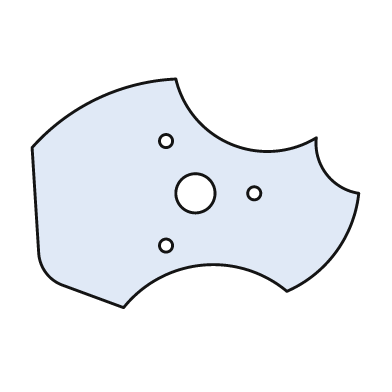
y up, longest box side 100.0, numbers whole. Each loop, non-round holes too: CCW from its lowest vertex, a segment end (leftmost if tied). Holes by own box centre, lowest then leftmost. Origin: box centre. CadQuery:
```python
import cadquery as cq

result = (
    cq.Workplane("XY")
    .moveTo(-22.0, -35.0)
    .threePointArc((2.0, -22.0), (28.0, -30.0))
    .threePointArc((43.0, -18.0), (50.0, 0.0))
    .threePointArc((40.0, 6.0), (37.0, 17.0))
    .threePointArc((11.0, 15.0), (-6.0, 35.0))
    .threePointArc((-30.0, 29.0), (-50.0, 14.0))
    .lineTo(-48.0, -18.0)
    .threePointArc((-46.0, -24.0), (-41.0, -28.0))
    .close()
    .moveTo(-9.0, -16.0)
    .circle(2.0)
    .moveTo(0.0, 0.0)
    .circle(6.0)
    .moveTo(18.0, 0.0)
    .circle(2.0)
    .moveTo(-9.0, 16.0)
    .circle(2.0)
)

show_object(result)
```